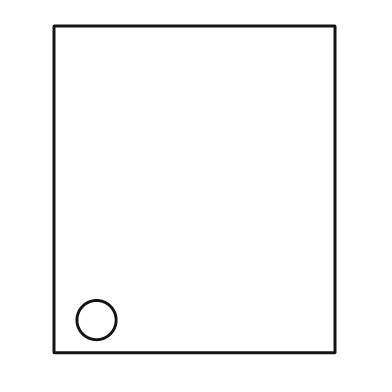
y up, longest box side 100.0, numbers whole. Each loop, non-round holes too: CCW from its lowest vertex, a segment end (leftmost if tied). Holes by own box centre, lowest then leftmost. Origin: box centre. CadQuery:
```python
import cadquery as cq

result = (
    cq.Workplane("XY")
    .moveTo(-43.0, -50.0)
    .lineTo(43.0, -50.0)
    .lineTo(43.0, 50.0)
    .lineTo(-43.0, 50.0)
    .close()
    .moveTo(-30.0, -40.0)
    .circle(6.0)
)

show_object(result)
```